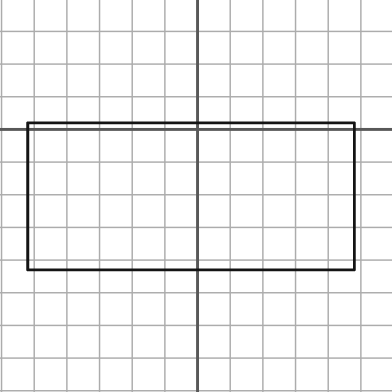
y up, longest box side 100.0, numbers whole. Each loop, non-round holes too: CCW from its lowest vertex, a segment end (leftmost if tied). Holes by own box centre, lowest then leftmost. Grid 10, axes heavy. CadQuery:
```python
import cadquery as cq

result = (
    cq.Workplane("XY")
    .moveTo(-52.0, -43.0)
    .lineTo(48.0, -43.0)
    .lineTo(48.0, 2.0)
    .lineTo(-52.0, 2.0)
    .close()
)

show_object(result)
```